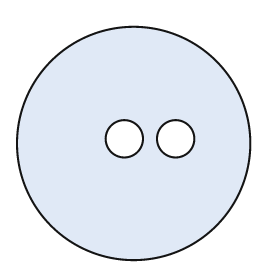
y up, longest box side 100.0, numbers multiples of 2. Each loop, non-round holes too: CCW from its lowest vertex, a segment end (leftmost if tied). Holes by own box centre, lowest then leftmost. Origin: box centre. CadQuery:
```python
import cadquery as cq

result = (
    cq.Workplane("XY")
    .moveTo(0.0, 0.0)
    .circle(50.0)
    .moveTo(-4.0, 2.0)
    .circle(8.0)
    .moveTo(18.0, 2.0)
    .circle(8.0)
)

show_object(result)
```